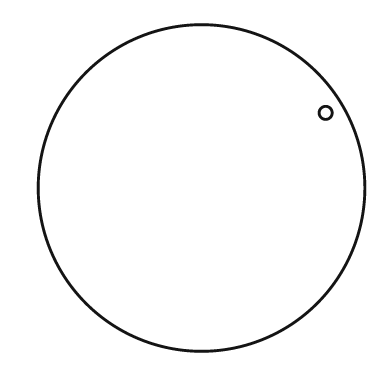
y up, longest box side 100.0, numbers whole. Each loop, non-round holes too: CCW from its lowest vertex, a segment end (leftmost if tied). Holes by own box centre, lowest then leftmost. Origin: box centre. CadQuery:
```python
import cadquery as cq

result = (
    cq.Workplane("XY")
    .moveTo(0.0, 0.0)
    .circle(50.0)
    .moveTo(38.0, 23.0)
    .circle(2.0)
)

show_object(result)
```